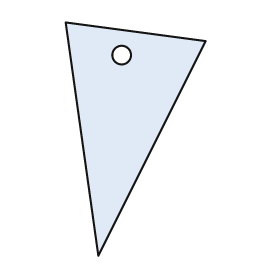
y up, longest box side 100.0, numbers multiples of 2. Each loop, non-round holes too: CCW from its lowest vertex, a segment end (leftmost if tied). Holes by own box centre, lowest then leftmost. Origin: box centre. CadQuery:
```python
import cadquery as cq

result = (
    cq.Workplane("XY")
    .moveTo(-16.0, -50.0)
    .lineTo(30.0, 42.0)
    .lineTo(-30.0, 50.0)
    .close()
    .moveTo(-6.0, 36.0)
    .circle(4.0)
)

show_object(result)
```